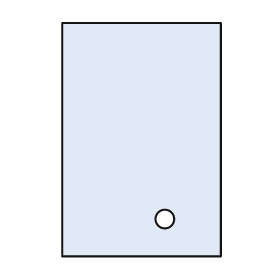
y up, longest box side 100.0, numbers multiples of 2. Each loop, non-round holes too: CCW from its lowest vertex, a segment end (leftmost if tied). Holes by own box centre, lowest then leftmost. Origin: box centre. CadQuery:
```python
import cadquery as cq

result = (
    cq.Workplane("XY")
    .moveTo(-34.0, -50.0)
    .lineTo(34.0, -50.0)
    .lineTo(34.0, 50.0)
    .lineTo(-34.0, 50.0)
    .close()
    .moveTo(10.0, -34.0)
    .circle(4.0)
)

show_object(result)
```